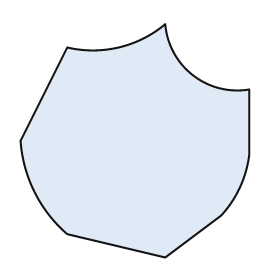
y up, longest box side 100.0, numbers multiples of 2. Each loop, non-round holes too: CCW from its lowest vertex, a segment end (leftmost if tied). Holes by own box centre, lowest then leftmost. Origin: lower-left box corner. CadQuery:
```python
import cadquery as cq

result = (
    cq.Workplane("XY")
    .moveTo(62.0, 0.0)
    .lineTo(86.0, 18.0)
    .threePointArc((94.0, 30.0), (98.0, 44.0))
    .lineTo(98.0, 72.0)
    .threePointArc((74.0, 78.0), (62.0, 100.0))
    .threePointArc((42.0, 90.0), (20.0, 90.0))
    .lineTo(0.0, 50.0)
    .threePointArc((6.0, 28.0), (20.0, 10.0))
    .close()
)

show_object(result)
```